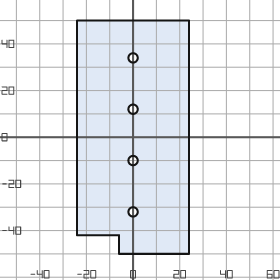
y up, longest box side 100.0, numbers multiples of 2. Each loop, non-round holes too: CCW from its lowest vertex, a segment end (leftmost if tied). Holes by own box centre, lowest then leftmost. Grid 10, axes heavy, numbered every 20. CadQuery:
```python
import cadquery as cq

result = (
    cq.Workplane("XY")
    .moveTo(-6.0, -50.0)
    .lineTo(24.0, -50.0)
    .lineTo(24.0, 50.0)
    .lineTo(-24.0, 50.0)
    .lineTo(-24.0, -42.0)
    .lineTo(-6.0, -42.0)
    .close()
    .moveTo(0.0, -32.0)
    .circle(2.0)
    .moveTo(0.0, -10.0)
    .circle(2.0)
    .moveTo(0.0, 12.0)
    .circle(2.0)
    .moveTo(0.0, 34.0)
    .circle(2.0)
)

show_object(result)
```